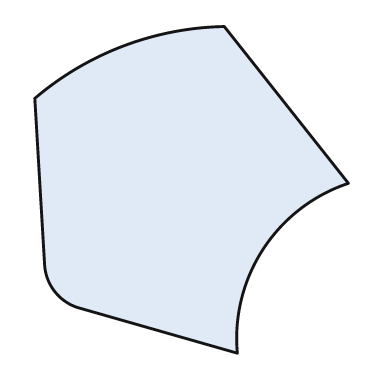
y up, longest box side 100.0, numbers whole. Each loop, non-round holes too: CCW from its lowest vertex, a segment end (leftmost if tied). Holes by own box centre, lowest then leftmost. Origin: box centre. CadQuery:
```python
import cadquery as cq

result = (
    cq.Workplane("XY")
    .moveTo(14.0, -50.0)
    .threePointArc((22.0, -18.0), (48.0, 2.0))
    .lineTo(10.0, 50.0)
    .threePointArc((-21.0, 44.0), (-48.0, 28.0))
    .lineTo(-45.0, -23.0)
    .threePointArc((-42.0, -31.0), (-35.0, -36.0))
    .close()
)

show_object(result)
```